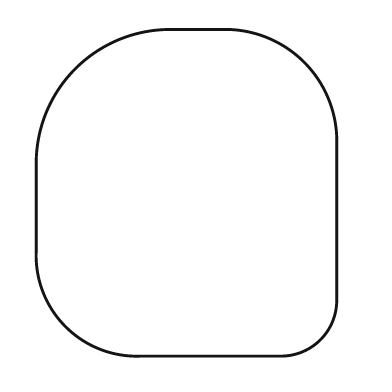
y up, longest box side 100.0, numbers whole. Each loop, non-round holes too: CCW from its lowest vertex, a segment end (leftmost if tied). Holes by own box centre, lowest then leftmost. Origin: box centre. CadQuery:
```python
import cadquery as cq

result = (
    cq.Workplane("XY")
    .moveTo(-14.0, -50.0)
    .lineTo(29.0, -50.0)
    .threePointArc((41.0, -45.0), (46.0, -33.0))
    .lineTo(46.0, 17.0)
    .threePointArc((36.0, 40.0), (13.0, 50.0))
    .lineTo(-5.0, 50.0)
    .threePointArc((-34.0, 38.0), (-46.0, 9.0))
    .lineTo(-46.0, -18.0)
    .threePointArc((-37.0, -41.0), (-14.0, -50.0))
    .close()
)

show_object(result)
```